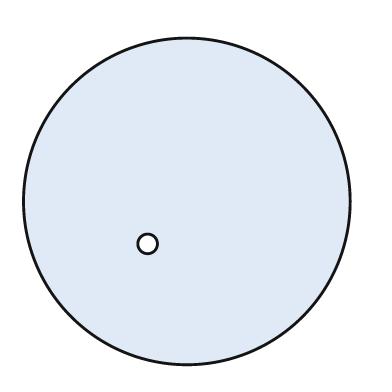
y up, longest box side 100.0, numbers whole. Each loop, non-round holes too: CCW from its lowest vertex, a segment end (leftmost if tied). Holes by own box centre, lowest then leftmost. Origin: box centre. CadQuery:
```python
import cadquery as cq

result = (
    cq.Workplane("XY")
    .moveTo(0.0, 0.0)
    .circle(50.0)
    .moveTo(-12.0, -13.0)
    .circle(3.0)
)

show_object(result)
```